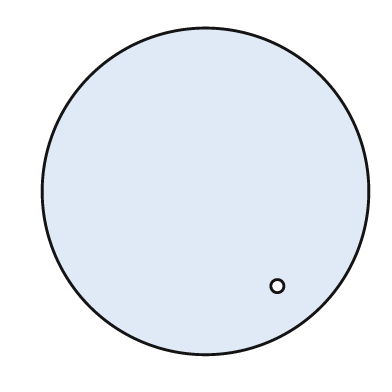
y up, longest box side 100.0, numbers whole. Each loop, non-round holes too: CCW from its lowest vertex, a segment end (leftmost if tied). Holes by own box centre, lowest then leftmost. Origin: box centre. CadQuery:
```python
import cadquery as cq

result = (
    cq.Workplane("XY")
    .moveTo(0.0, 0.0)
    .circle(50.0)
    .moveTo(22.0, -29.0)
    .circle(2.0)
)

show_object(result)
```